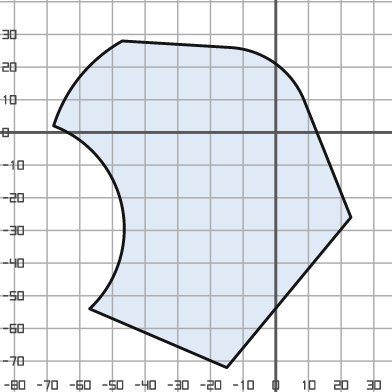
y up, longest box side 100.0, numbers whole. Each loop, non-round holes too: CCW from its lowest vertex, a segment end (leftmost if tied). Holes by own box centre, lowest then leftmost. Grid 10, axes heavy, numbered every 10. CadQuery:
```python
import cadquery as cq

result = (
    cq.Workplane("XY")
    .moveTo(-15.0, -72.0)
    .lineTo(23.0, -26.0)
    .lineTo(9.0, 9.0)
    .threePointArc((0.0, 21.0), (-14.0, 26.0))
    .lineTo(-47.0, 28.0)
    .threePointArc((-60.0, 17.0), (-68.0, 2.0))
    .threePointArc((-47.0, -23.0), (-57.0, -54.0))
    .close()
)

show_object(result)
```